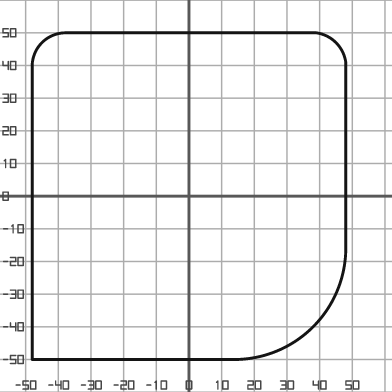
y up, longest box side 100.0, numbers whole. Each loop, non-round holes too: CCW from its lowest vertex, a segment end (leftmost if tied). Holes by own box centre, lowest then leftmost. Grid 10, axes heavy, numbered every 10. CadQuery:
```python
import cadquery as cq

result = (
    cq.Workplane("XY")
    .moveTo(-48.0, -50.0)
    .lineTo(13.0, -50.0)
    .threePointArc((38.0, -40.0), (48.0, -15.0))
    .lineTo(48.0, 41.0)
    .threePointArc((45.0, 47.0), (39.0, 50.0))
    .lineTo(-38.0, 50.0)
    .threePointArc((-45.0, 47.0), (-48.0, 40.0))
    .close()
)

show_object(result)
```